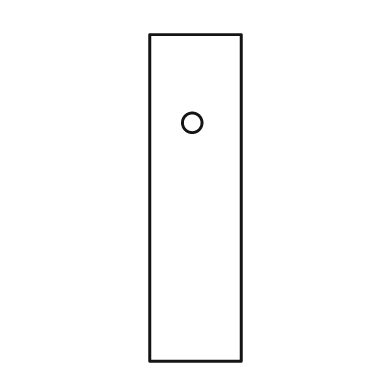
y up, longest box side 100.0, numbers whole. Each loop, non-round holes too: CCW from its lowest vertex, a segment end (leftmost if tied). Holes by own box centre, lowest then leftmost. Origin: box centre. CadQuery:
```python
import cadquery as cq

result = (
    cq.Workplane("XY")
    .moveTo(-14.0, -50.0)
    .lineTo(14.0, -50.0)
    .lineTo(14.0, 50.0)
    .lineTo(-14.0, 50.0)
    .close()
    .moveTo(-1.0, 23.0)
    .circle(3.0)
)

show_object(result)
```